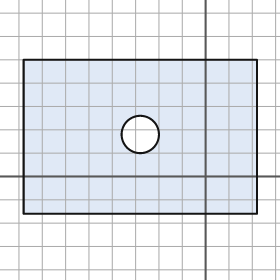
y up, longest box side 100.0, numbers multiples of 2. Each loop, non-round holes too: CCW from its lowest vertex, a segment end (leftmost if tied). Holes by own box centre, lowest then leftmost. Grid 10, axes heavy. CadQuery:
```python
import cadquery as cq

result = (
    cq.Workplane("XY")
    .moveTo(-78.0, -16.0)
    .lineTo(22.0, -16.0)
    .lineTo(22.0, 50.0)
    .lineTo(-78.0, 50.0)
    .close()
    .moveTo(-28.0, 18.0)
    .circle(8.0)
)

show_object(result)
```